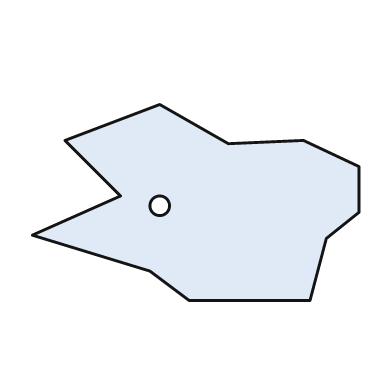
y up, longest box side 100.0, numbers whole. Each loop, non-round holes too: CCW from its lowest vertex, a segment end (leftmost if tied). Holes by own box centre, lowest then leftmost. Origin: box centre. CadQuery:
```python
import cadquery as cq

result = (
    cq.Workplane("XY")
    .moveTo(-2.0, -30.0)
    .lineTo(35.0, -30.0)
    .lineTo(40.0, -11.0)
    .lineTo(50.0, -3.0)
    .lineTo(50.0, 11.0)
    .lineTo(33.0, 19.0)
    .lineTo(10.0, 18.0)
    .lineTo(-11.0, 30.0)
    .lineTo(-40.0, 19.0)
    .lineTo(-23.0, 2.0)
    .lineTo(-50.0, -10.0)
    .lineTo(-14.0, -21.0)
    .close()
    .moveTo(-11.0, -1.0)
    .circle(3.0)
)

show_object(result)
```